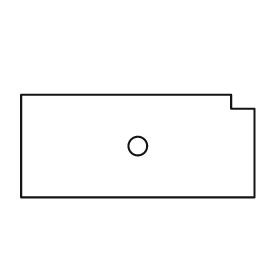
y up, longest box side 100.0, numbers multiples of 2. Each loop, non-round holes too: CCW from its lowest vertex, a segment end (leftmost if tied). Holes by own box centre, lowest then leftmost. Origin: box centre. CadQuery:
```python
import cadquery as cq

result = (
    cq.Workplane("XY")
    .moveTo(-50.0, -22.0)
    .lineTo(50.0, -22.0)
    .lineTo(50.0, 16.0)
    .lineTo(40.0, 16.0)
    .lineTo(40.0, 22.0)
    .lineTo(-50.0, 22.0)
    .close()
    .moveTo(0.0, 0.0)
    .circle(4.0)
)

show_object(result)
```